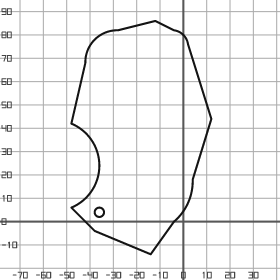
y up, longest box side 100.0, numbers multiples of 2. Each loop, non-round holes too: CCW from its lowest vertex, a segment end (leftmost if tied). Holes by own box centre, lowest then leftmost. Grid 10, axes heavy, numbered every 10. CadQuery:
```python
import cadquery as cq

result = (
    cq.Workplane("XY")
    .moveTo(-14.0, -14.0)
    .lineTo(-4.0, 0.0)
    .threePointArc((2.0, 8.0), (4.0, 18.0))
    .lineTo(12.0, 44.0)
    .lineTo(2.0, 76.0)
    .threePointArc((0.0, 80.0), (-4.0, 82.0))
    .lineTo(-12.0, 86.0)
    .lineTo(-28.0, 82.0)
    .threePointArc((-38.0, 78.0), (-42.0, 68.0))
    .lineTo(-48.0, 42.0)
    .threePointArc((-36.0, 24.0), (-48.0, 6.0))
    .lineTo(-38.0, -4.0)
    .close()
    .moveTo(-36.0, 4.0)
    .circle(2.0)
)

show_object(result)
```